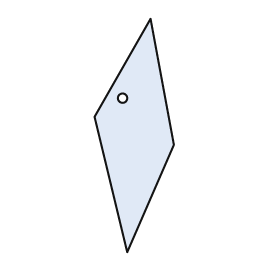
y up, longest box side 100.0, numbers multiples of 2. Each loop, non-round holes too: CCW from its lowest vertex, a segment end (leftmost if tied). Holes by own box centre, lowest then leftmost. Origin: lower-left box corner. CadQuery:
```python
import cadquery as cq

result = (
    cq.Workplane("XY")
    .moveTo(14.0, 0.0)
    .lineTo(34.0, 46.0)
    .lineTo(24.0, 100.0)
    .lineTo(0.0, 58.0)
    .close()
    .moveTo(12.0, 66.0)
    .circle(2.0)
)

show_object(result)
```